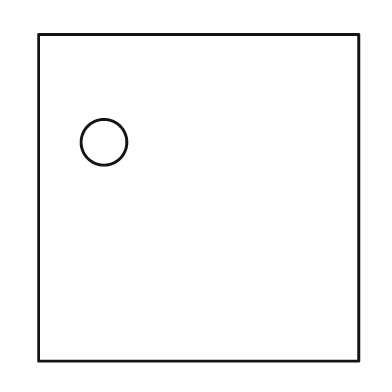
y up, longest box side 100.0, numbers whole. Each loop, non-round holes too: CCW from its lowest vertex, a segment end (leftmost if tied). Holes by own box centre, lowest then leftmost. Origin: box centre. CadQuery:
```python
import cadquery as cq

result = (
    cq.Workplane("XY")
    .moveTo(-49.0, -50.0)
    .lineTo(49.0, -50.0)
    .lineTo(49.0, 50.0)
    .lineTo(-49.0, 50.0)
    .close()
    .moveTo(-29.0, 17.0)
    .circle(7.0)
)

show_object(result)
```